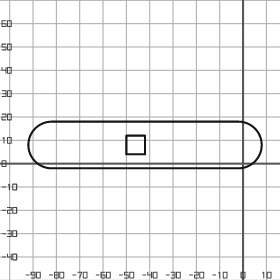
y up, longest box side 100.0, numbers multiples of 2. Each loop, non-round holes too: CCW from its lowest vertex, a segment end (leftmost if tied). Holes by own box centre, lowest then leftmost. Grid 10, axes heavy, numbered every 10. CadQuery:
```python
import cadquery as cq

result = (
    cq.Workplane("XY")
    .moveTo(-82.0, -2.0)
    .lineTo(-2.0, -2.0)
    .threePointArc((8.0, 8.0), (-2.0, 18.0))
    .lineTo(-82.0, 18.0)
    .threePointArc((-92.0, 8.0), (-82.0, -2.0))
    .close()
    .moveTo(-50.0, 4.0)
    .lineTo(-42.0, 4.0)
    .lineTo(-42.0, 12.0)
    .lineTo(-50.0, 12.0)
    .close()
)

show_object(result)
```